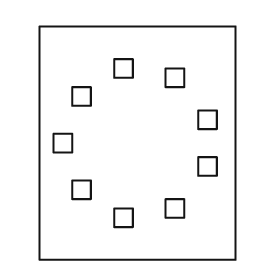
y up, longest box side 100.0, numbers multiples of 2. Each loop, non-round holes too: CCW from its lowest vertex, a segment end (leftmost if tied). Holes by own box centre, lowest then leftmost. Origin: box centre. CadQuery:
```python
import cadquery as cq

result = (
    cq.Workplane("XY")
    .moveTo(-42.0, -50.0)
    .lineTo(42.0, -50.0)
    .lineTo(42.0, 50.0)
    .lineTo(-42.0, 50.0)
    .close()
    .moveTo(-10.0, -36.0)
    .lineTo(-2.0, -36.0)
    .lineTo(-2.0, -28.0)
    .lineTo(-10.0, -28.0)
    .close()
    .moveTo(12.0, -32.0)
    .lineTo(20.0, -32.0)
    .lineTo(20.0, -24.0)
    .lineTo(12.0, -24.0)
    .close()
    .moveTo(-28.0, -24.0)
    .lineTo(-20.0, -24.0)
    .lineTo(-20.0, -16.0)
    .lineTo(-28.0, -16.0)
    .close()
    .moveTo(26.0, -14.0)
    .lineTo(34.0, -14.0)
    .lineTo(34.0, -6.0)
    .lineTo(26.0, -6.0)
    .close()
    .moveTo(-36.0, -4.0)
    .lineTo(-28.0, -4.0)
    .lineTo(-28.0, 4.0)
    .lineTo(-36.0, 4.0)
    .close()
    .moveTo(26.0, 6.0)
    .lineTo(34.0, 6.0)
    .lineTo(34.0, 14.0)
    .lineTo(26.0, 14.0)
    .close()
    .moveTo(-28.0, 16.0)
    .lineTo(-20.0, 16.0)
    .lineTo(-20.0, 24.0)
    .lineTo(-28.0, 24.0)
    .close()
    .moveTo(12.0, 24.0)
    .lineTo(20.0, 24.0)
    .lineTo(20.0, 32.0)
    .lineTo(12.0, 32.0)
    .close()
    .moveTo(-10.0, 28.0)
    .lineTo(-2.0, 28.0)
    .lineTo(-2.0, 36.0)
    .lineTo(-10.0, 36.0)
    .close()
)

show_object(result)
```